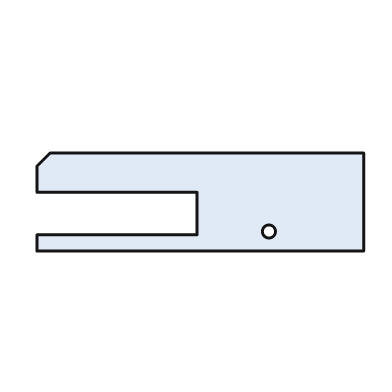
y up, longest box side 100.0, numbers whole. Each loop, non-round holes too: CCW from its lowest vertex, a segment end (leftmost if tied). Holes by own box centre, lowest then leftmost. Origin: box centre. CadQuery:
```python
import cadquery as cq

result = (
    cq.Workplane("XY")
    .moveTo(-50.0, -15.0)
    .lineTo(50.0, -15.0)
    .lineTo(50.0, 15.0)
    .lineTo(-46.0, 15.0)
    .lineTo(-50.0, 11.0)
    .lineTo(-50.0, 3.0)
    .lineTo(-1.0, 3.0)
    .lineTo(-1.0, -10.0)
    .lineTo(-50.0, -10.0)
    .close()
    .moveTo(21.0, -9.0)
    .circle(2.0)
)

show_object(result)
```